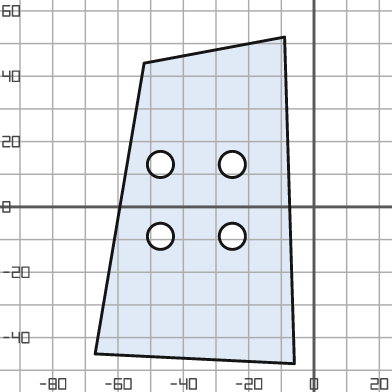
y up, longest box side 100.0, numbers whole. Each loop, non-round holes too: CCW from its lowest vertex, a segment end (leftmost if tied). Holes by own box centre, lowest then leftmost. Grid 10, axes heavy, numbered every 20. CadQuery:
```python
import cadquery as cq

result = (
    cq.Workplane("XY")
    .moveTo(-6.0, -48.0)
    .lineTo(-9.0, 52.0)
    .lineTo(-52.0, 44.0)
    .lineTo(-67.0, -45.0)
    .close()
    .moveTo(-47.0, -9.0)
    .circle(4.0)
    .moveTo(-25.0, -9.0)
    .circle(4.0)
    .moveTo(-47.0, 13.0)
    .circle(4.0)
    .moveTo(-25.0, 13.0)
    .circle(4.0)
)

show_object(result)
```